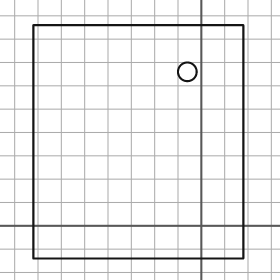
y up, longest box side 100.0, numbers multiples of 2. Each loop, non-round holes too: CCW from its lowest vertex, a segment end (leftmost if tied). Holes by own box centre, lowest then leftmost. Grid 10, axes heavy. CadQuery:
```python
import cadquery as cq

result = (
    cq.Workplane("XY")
    .moveTo(-72.0, -14.0)
    .lineTo(18.0, -14.0)
    .lineTo(18.0, 86.0)
    .lineTo(-72.0, 86.0)
    .close()
    .moveTo(-6.0, 66.0)
    .circle(4.0)
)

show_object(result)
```